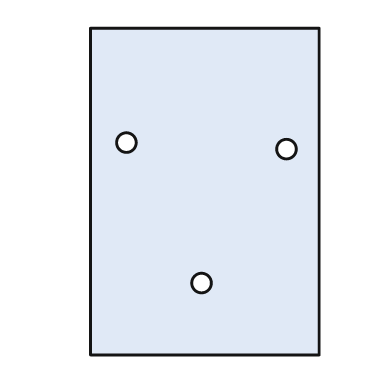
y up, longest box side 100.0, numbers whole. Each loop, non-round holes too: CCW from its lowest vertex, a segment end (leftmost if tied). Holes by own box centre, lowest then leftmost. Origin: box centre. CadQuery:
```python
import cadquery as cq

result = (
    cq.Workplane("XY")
    .moveTo(-35.0, -50.0)
    .lineTo(35.0, -50.0)
    .lineTo(35.0, 50.0)
    .lineTo(-35.0, 50.0)
    .close()
    .moveTo(-1.0, -28.0)
    .circle(3.0)
    .moveTo(25.0, 13.0)
    .circle(3.0)
    .moveTo(-24.0, 15.0)
    .circle(3.0)
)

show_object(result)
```